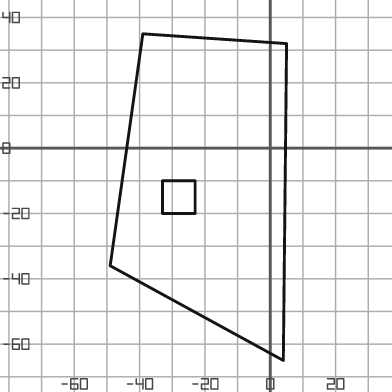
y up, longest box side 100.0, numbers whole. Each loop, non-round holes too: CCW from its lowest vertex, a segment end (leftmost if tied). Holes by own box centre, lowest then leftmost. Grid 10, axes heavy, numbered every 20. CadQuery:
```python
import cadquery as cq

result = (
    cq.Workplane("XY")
    .moveTo(4.0, -65.0)
    .lineTo(5.0, 32.0)
    .lineTo(-39.0, 35.0)
    .lineTo(-49.0, -36.0)
    .close()
    .moveTo(-33.0, -20.0)
    .lineTo(-23.0, -20.0)
    .lineTo(-23.0, -10.0)
    .lineTo(-33.0, -10.0)
    .close()
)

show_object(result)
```